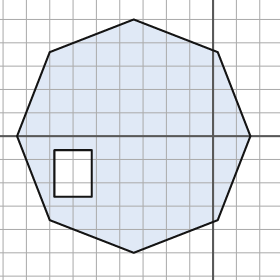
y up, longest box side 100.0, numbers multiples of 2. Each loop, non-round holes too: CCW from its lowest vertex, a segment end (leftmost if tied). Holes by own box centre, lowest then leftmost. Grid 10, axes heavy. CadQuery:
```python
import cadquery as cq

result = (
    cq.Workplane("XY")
    .moveTo(-34.0, -50.0)
    .lineTo(2.0, -36.0)
    .lineTo(16.0, 0.0)
    .lineTo(2.0, 36.0)
    .lineTo(-34.0, 50.0)
    .lineTo(-70.0, 36.0)
    .lineTo(-84.0, 0.0)
    .lineTo(-70.0, -36.0)
    .close()
    .moveTo(-68.0, -26.0)
    .lineTo(-52.0, -26.0)
    .lineTo(-52.0, -6.0)
    .lineTo(-68.0, -6.0)
    .close()
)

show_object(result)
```